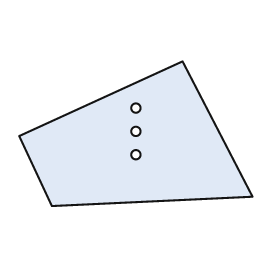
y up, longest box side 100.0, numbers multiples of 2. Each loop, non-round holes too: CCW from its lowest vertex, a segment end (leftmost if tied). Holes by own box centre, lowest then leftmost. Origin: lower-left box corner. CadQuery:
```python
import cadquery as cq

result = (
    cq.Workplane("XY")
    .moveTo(14.0, 0.0)
    .lineTo(100.0, 4.0)
    .lineTo(70.0, 62.0)
    .lineTo(0.0, 30.0)
    .close()
    .moveTo(50.0, 22.0)
    .circle(2.0)
    .moveTo(50.0, 32.0)
    .circle(2.0)
    .moveTo(50.0, 42.0)
    .circle(2.0)
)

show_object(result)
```